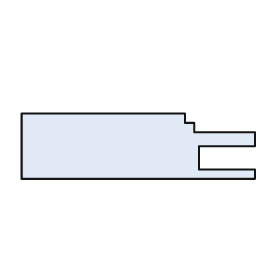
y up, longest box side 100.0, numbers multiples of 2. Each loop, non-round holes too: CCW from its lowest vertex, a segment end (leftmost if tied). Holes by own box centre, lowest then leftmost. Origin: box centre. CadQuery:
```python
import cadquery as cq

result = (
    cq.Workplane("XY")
    .moveTo(-50.0, -14.0)
    .lineTo(50.0, -14.0)
    .lineTo(50.0, -10.0)
    .lineTo(26.0, -10.0)
    .lineTo(26.0, 0.0)
    .lineTo(50.0, 0.0)
    .lineTo(50.0, 6.0)
    .lineTo(24.0, 6.0)
    .lineTo(24.0, 10.0)
    .lineTo(20.0, 10.0)
    .lineTo(20.0, 14.0)
    .lineTo(-50.0, 14.0)
    .close()
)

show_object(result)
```